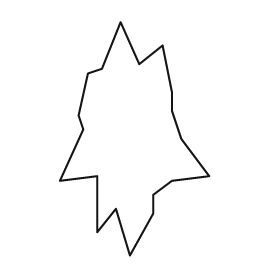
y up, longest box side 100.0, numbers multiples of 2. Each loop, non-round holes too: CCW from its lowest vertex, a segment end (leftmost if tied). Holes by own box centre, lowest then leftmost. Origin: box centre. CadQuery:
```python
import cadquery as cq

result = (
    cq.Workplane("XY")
    .moveTo(-2.0, -50.0)
    .lineTo(8.0, -32.0)
    .lineTo(8.0, -24.0)
    .lineTo(16.0, -18.0)
    .lineTo(32.0, -16.0)
    .lineTo(20.0, 0.0)
    .lineTo(16.0, 12.0)
    .lineTo(16.0, 20.0)
    .lineTo(12.0, 40.0)
    .lineTo(2.0, 32.0)
    .lineTo(-6.0, 50.0)
    .lineTo(-14.0, 30.0)
    .lineTo(-20.0, 28.0)
    .lineTo(-24.0, 10.0)
    .lineTo(-22.0, 4.0)
    .lineTo(-32.0, -18.0)
    .lineTo(-16.0, -16.0)
    .lineTo(-16.0, -40.0)
    .lineTo(-8.0, -30.0)
    .close()
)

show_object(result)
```